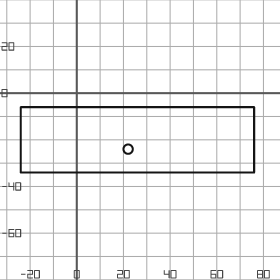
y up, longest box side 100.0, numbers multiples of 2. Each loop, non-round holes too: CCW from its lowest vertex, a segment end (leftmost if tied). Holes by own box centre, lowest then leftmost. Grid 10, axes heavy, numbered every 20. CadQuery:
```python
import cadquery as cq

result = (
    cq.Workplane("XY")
    .moveTo(-24.0, -34.0)
    .lineTo(76.0, -34.0)
    .lineTo(76.0, -6.0)
    .lineTo(-24.0, -6.0)
    .close()
    .moveTo(22.0, -24.0)
    .circle(2.0)
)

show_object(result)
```